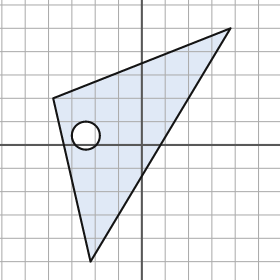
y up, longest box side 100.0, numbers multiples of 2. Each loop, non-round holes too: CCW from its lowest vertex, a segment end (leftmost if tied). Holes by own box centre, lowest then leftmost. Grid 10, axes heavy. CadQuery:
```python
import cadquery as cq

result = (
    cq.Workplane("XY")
    .moveTo(-22.0, -50.0)
    .lineTo(38.0, 50.0)
    .lineTo(-38.0, 20.0)
    .close()
    .moveTo(-24.0, 4.0)
    .circle(6.0)
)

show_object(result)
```